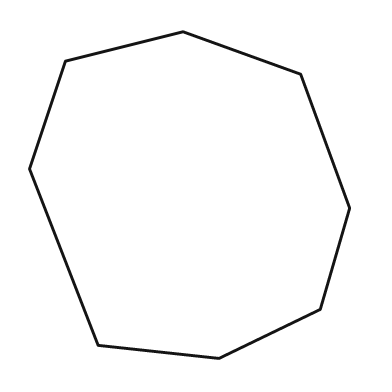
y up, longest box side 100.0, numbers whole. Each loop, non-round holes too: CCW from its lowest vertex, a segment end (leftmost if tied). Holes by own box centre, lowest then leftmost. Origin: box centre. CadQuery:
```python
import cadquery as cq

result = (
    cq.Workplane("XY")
    .moveTo(9.0, -50.0)
    .lineTo(40.0, -35.0)
    .lineTo(49.0, -4.0)
    .lineTo(34.0, 37.0)
    .lineTo(-2.0, 50.0)
    .lineTo(-38.0, 41.0)
    .lineTo(-49.0, 8.0)
    .lineTo(-28.0, -46.0)
    .close()
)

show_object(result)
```